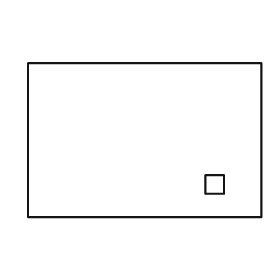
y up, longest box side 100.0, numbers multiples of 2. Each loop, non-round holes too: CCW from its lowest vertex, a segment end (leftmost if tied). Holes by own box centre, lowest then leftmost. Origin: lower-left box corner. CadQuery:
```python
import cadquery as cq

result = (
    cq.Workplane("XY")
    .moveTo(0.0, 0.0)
    .lineTo(100.0, 0.0)
    .lineTo(100.0, 66.0)
    .lineTo(0.0, 66.0)
    .close()
    .moveTo(76.0, 10.0)
    .lineTo(84.0, 10.0)
    .lineTo(84.0, 18.0)
    .lineTo(76.0, 18.0)
    .close()
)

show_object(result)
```